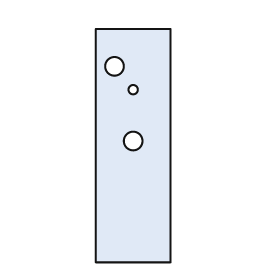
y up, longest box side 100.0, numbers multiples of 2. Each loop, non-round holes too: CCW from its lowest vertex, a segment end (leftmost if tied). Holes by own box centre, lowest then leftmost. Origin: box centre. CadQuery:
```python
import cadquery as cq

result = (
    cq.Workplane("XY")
    .moveTo(-16.0, -50.0)
    .lineTo(16.0, -50.0)
    .lineTo(16.0, 50.0)
    .lineTo(-16.0, 50.0)
    .close()
    .moveTo(0.0, 2.0)
    .circle(4.0)
    .moveTo(0.0, 24.0)
    .circle(2.0)
    .moveTo(-8.0, 34.0)
    .circle(4.0)
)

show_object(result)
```